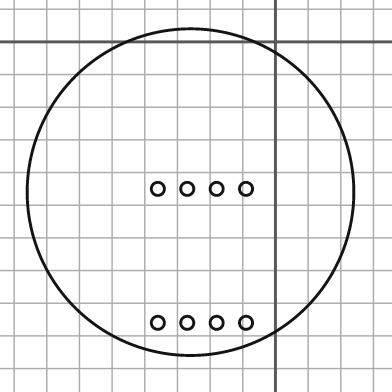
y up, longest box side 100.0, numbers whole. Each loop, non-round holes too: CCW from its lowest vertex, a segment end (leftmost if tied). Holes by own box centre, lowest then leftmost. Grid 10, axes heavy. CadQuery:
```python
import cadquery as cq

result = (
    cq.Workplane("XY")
    .moveTo(-26.0, -46.0)
    .circle(50.0)
    .moveTo(-36.0, -86.0)
    .circle(2.0)
    .moveTo(-27.0, -86.0)
    .circle(2.0)
    .moveTo(-18.0, -86.0)
    .circle(2.0)
    .moveTo(-9.0, -86.0)
    .circle(2.0)
    .moveTo(-36.0, -45.0)
    .circle(2.0)
    .moveTo(-27.0, -45.0)
    .circle(2.0)
    .moveTo(-18.0, -45.0)
    .circle(2.0)
    .moveTo(-9.0, -45.0)
    .circle(2.0)
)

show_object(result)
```